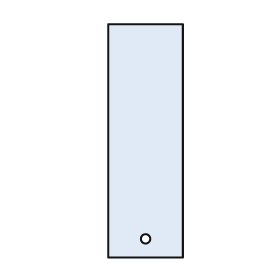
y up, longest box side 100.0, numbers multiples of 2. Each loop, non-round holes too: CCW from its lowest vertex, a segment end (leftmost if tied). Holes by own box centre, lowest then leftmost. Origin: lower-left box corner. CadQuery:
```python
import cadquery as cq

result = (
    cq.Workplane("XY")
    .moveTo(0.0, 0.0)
    .lineTo(32.0, 0.0)
    .lineTo(32.0, 100.0)
    .lineTo(0.0, 100.0)
    .close()
    .moveTo(16.0, 8.0)
    .circle(2.0)
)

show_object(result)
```